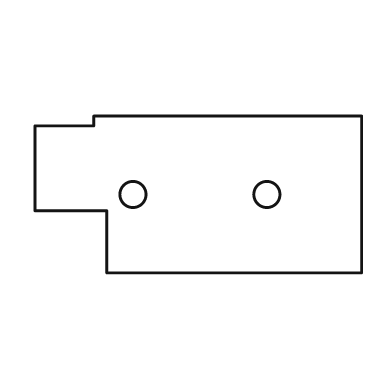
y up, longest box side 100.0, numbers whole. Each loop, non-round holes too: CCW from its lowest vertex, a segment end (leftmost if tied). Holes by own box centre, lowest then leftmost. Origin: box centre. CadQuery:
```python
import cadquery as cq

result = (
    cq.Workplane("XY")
    .moveTo(-28.0, -24.0)
    .lineTo(50.0, -24.0)
    .lineTo(50.0, 24.0)
    .lineTo(-32.0, 24.0)
    .lineTo(-32.0, 21.0)
    .lineTo(-50.0, 21.0)
    .lineTo(-50.0, -5.0)
    .lineTo(-28.0, -5.0)
    .close()
    .moveTo(-20.0, 0.0)
    .circle(4.0)
    .moveTo(21.0, 0.0)
    .circle(4.0)
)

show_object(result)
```